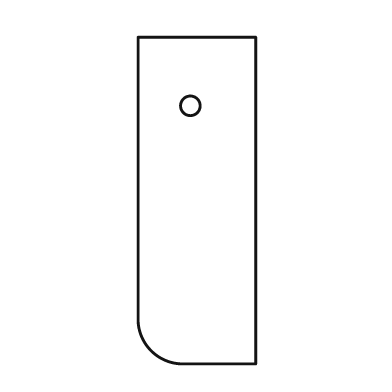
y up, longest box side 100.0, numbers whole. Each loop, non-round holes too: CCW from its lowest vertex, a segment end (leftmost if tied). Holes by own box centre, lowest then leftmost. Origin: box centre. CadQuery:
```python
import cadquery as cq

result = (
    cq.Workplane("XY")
    .moveTo(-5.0, -50.0)
    .lineTo(18.0, -50.0)
    .lineTo(18.0, 50.0)
    .lineTo(-18.0, 50.0)
    .lineTo(-18.0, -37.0)
    .threePointArc((-14.0, -46.0), (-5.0, -50.0))
    .close()
    .moveTo(-2.0, 29.0)
    .circle(3.0)
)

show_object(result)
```